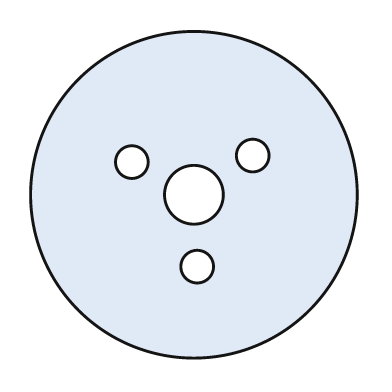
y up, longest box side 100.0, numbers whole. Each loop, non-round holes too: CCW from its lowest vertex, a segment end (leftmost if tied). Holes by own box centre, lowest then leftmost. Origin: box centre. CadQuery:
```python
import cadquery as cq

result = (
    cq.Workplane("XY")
    .moveTo(0.0, 0.0)
    .circle(50.0)
    .moveTo(1.0, -22.0)
    .circle(5.0)
    .moveTo(0.0, 0.0)
    .circle(9.0)
    .moveTo(-19.0, 10.0)
    .circle(5.0)
    .moveTo(18.0, 12.0)
    .circle(5.0)
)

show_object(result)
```